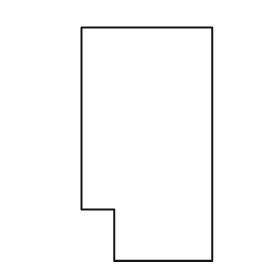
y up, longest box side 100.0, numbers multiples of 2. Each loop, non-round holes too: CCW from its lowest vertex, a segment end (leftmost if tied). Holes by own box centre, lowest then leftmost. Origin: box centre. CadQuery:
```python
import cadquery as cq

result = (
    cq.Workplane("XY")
    .moveTo(-14.0, -50.0)
    .lineTo(28.0, -50.0)
    .lineTo(28.0, 50.0)
    .lineTo(-28.0, 50.0)
    .lineTo(-28.0, -28.0)
    .lineTo(-14.0, -28.0)
    .close()
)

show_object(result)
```